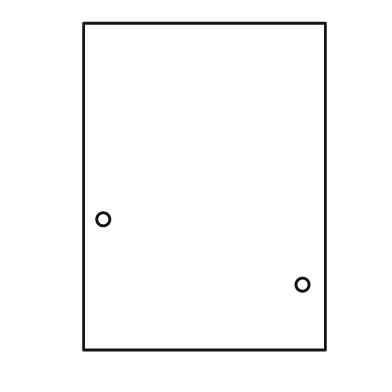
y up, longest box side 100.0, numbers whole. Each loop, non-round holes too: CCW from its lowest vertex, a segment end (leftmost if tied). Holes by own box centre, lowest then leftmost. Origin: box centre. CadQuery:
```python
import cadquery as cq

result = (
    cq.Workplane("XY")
    .moveTo(-37.0, -50.0)
    .lineTo(37.0, -50.0)
    .lineTo(37.0, 50.0)
    .lineTo(-37.0, 50.0)
    .close()
    .moveTo(30.0, -30.0)
    .circle(2.0)
    .moveTo(-31.0, -10.0)
    .circle(2.0)
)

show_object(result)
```